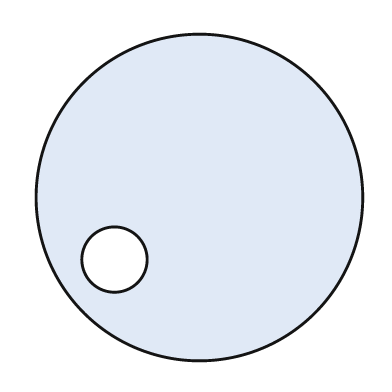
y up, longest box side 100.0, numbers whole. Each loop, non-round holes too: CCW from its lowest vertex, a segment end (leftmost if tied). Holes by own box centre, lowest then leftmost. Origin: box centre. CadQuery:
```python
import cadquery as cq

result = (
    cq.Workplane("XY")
    .moveTo(0.0, 0.0)
    .circle(50.0)
    .moveTo(-26.0, -19.0)
    .circle(10.0)
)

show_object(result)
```